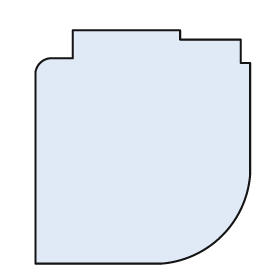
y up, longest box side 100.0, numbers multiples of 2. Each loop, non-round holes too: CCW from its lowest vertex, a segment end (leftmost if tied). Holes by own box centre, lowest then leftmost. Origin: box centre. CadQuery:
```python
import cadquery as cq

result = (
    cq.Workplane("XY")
    .moveTo(-46.0, -50.0)
    .lineTo(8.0, -50.0)
    .threePointArc((34.0, -38.0), (46.0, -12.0))
    .lineTo(46.0, 36.0)
    .lineTo(42.0, 36.0)
    .lineTo(42.0, 46.0)
    .lineTo(16.0, 46.0)
    .lineTo(16.0, 50.0)
    .lineTo(-30.0, 50.0)
    .lineTo(-30.0, 38.0)
    .lineTo(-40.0, 38.0)
    .threePointArc((-44.0, 36.0), (-46.0, 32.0))
    .close()
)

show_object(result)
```